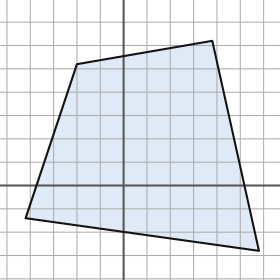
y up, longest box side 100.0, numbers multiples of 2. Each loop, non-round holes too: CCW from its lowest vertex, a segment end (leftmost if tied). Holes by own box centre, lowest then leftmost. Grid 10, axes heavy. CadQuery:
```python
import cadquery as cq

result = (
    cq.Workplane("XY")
    .moveTo(58.0, -28.0)
    .lineTo(38.0, 62.0)
    .lineTo(-20.0, 52.0)
    .lineTo(-42.0, -14.0)
    .close()
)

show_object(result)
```